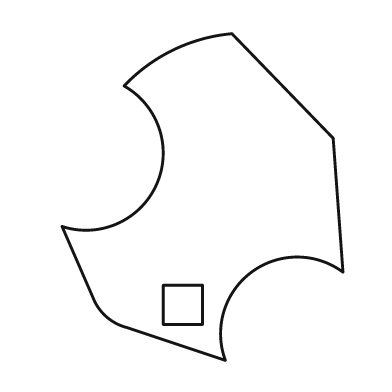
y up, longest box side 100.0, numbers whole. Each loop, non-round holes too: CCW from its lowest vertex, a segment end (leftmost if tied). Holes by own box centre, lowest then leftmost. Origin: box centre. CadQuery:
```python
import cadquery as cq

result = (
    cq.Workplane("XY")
    .moveTo(7.0, -50.0)
    .threePointArc((15.0, -23.0), (43.0, -23.0))
    .lineTo(40.0, 18.0)
    .lineTo(9.0, 50.0)
    .threePointArc((-9.0, 45.0), (-24.0, 34.0))
    .threePointArc((-14.0, 4.0), (-43.0, -9.0))
    .lineTo(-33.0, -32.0)
    .threePointArc((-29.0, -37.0), (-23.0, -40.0))
    .close()
    .moveTo(-12.0, -39.0)
    .lineTo(0.0, -39.0)
    .lineTo(0.0, -27.0)
    .lineTo(-12.0, -27.0)
    .close()
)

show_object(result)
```